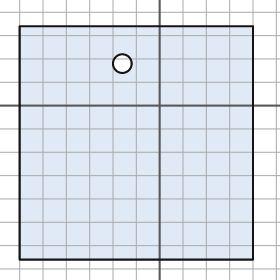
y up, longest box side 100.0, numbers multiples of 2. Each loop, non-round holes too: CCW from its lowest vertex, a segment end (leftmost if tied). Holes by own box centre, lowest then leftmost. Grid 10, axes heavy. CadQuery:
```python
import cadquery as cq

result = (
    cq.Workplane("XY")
    .moveTo(-60.0, -66.0)
    .lineTo(40.0, -66.0)
    .lineTo(40.0, 34.0)
    .lineTo(-60.0, 34.0)
    .close()
    .moveTo(-16.0, 18.0)
    .circle(4.0)
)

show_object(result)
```